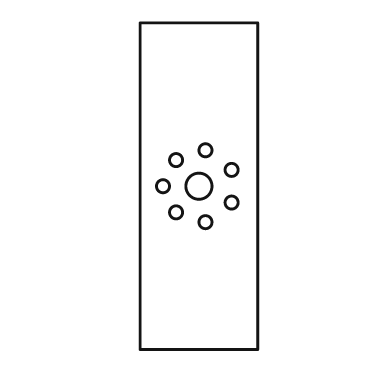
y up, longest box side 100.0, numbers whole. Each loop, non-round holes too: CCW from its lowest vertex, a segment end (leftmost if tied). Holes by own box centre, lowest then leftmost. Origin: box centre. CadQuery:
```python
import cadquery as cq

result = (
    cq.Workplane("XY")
    .moveTo(-18.0, -50.0)
    .lineTo(18.0, -50.0)
    .lineTo(18.0, 50.0)
    .lineTo(-18.0, 50.0)
    .close()
    .moveTo(2.0, -11.0)
    .circle(2.0)
    .moveTo(-7.0, -8.0)
    .circle(2.0)
    .moveTo(10.0, -5.0)
    .circle(2.0)
    .moveTo(-11.0, 0.0)
    .circle(2.0)
    .moveTo(0.0, 0.0)
    .circle(4.0)
    .moveTo(10.0, 5.0)
    .circle(2.0)
    .moveTo(-7.0, 8.0)
    .circle(2.0)
    .moveTo(2.0, 11.0)
    .circle(2.0)
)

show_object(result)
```